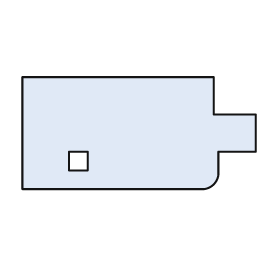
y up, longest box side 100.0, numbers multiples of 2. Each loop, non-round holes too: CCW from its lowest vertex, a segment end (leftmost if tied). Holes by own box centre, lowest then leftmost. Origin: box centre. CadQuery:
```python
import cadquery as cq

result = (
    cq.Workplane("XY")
    .moveTo(-50.0, -24.0)
    .lineTo(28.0, -24.0)
    .threePointArc((32.0, -22.0), (34.0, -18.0))
    .lineTo(34.0, -8.0)
    .lineTo(50.0, -8.0)
    .lineTo(50.0, 8.0)
    .lineTo(32.0, 8.0)
    .lineTo(32.0, 24.0)
    .lineTo(-50.0, 24.0)
    .close()
    .moveTo(-30.0, -16.0)
    .lineTo(-22.0, -16.0)
    .lineTo(-22.0, -8.0)
    .lineTo(-30.0, -8.0)
    .close()
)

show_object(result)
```